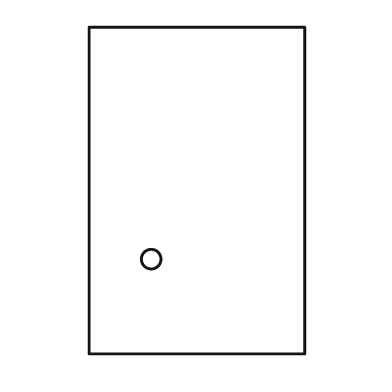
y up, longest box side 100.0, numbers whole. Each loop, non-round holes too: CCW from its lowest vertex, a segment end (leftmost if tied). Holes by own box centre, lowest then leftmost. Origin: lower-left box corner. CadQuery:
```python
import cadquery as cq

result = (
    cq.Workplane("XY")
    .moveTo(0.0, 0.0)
    .lineTo(66.0, 0.0)
    .lineTo(66.0, 100.0)
    .lineTo(0.0, 100.0)
    .close()
    .moveTo(19.0, 29.0)
    .circle(3.0)
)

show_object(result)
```